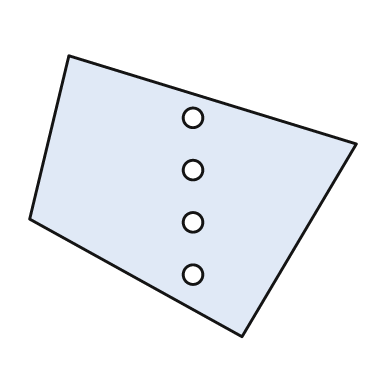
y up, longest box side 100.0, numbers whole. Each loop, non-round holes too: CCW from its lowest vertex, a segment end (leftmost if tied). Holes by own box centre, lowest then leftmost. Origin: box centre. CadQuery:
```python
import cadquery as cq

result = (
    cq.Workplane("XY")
    .moveTo(15.0, -43.0)
    .lineTo(50.0, 16.0)
    .lineTo(-38.0, 43.0)
    .lineTo(-50.0, -7.0)
    .close()
    .moveTo(0.0, -24.0)
    .circle(3.0)
    .moveTo(0.0, -8.0)
    .circle(3.0)
    .moveTo(0.0, 8.0)
    .circle(3.0)
    .moveTo(0.0, 24.0)
    .circle(3.0)
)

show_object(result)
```